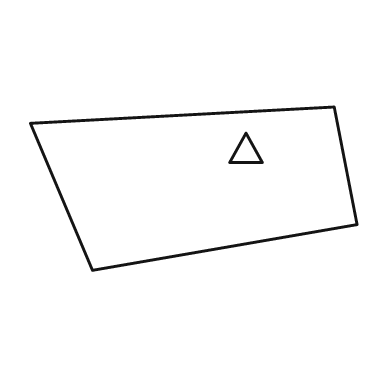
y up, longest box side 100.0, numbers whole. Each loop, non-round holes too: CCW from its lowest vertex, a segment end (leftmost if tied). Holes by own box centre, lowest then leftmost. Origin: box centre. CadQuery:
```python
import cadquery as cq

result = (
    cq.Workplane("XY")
    .moveTo(-31.0, -25.0)
    .lineTo(50.0, -11.0)
    .lineTo(43.0, 25.0)
    .lineTo(-50.0, 20.0)
    .close()
    .moveTo(11.0, 8.0)
    .lineTo(21.0, 8.0)
    .lineTo(16.0, 17.0)
    .close()
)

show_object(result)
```